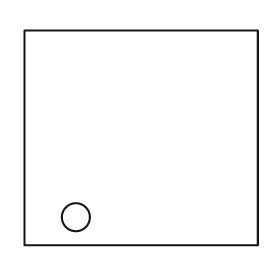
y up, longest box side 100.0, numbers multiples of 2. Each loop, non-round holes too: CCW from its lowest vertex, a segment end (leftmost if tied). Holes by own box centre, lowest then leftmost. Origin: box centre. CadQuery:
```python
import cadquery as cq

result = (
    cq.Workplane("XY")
    .moveTo(-50.0, -46.0)
    .lineTo(50.0, -46.0)
    .lineTo(50.0, 46.0)
    .lineTo(-50.0, 46.0)
    .close()
    .moveTo(-28.0, -34.0)
    .circle(6.0)
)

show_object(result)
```